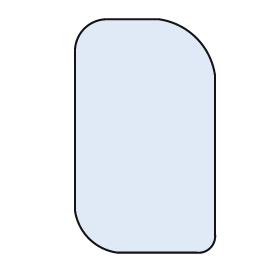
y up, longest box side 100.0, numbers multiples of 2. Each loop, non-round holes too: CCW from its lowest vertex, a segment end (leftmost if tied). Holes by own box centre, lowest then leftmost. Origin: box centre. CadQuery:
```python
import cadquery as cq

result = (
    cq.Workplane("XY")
    .moveTo(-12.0, -50.0)
    .lineTo(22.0, -50.0)
    .threePointArc((28.0, -48.0), (30.0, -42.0))
    .lineTo(30.0, 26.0)
    .threePointArc((22.0, 42.0), (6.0, 50.0))
    .lineTo(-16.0, 50.0)
    .threePointArc((-26.0, 46.0), (-30.0, 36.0))
    .lineTo(-30.0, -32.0)
    .threePointArc((-24.0, -44.0), (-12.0, -50.0))
    .close()
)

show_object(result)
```